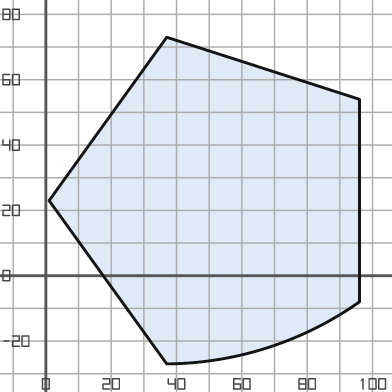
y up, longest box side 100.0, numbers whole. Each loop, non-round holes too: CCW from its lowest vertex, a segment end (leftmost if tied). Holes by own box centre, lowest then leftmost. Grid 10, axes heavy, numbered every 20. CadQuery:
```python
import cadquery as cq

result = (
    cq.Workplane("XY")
    .moveTo(37.0, -27.0)
    .threePointArc((68.0, -22.0), (96.0, -8.0))
    .lineTo(96.0, 54.0)
    .lineTo(37.0, 73.0)
    .lineTo(1.0, 23.0)
    .close()
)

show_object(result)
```